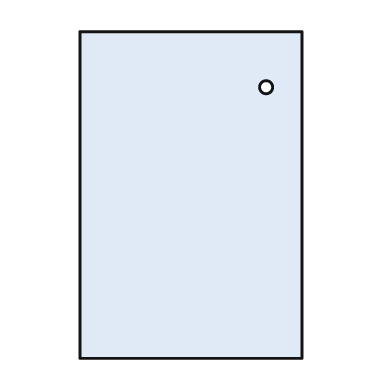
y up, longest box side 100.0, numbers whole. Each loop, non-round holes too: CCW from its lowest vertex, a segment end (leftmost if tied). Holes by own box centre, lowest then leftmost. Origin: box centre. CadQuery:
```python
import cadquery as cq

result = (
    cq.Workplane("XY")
    .moveTo(-34.0, -50.0)
    .lineTo(34.0, -50.0)
    .lineTo(34.0, 50.0)
    .lineTo(-34.0, 50.0)
    .close()
    .moveTo(23.0, 33.0)
    .circle(2.0)
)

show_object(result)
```